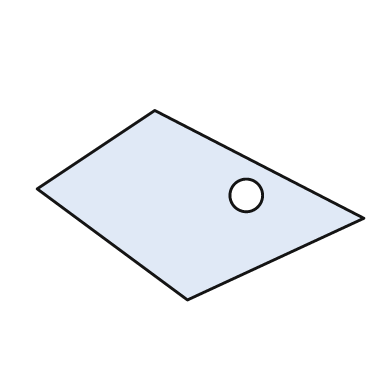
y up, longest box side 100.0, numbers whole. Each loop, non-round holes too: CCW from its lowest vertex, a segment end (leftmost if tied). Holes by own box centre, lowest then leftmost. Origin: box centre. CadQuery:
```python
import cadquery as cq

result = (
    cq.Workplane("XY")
    .moveTo(-4.0, -29.0)
    .lineTo(50.0, -4.0)
    .lineTo(-14.0, 29.0)
    .lineTo(-50.0, 5.0)
    .close()
    .moveTo(14.0, 3.0)
    .circle(5.0)
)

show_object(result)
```